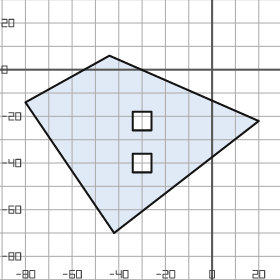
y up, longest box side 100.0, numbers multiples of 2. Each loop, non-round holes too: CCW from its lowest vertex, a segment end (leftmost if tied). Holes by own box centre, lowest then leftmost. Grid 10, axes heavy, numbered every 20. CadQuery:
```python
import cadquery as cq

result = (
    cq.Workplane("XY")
    .moveTo(-42.0, -70.0)
    .lineTo(20.0, -22.0)
    .lineTo(-44.0, 6.0)
    .lineTo(-80.0, -14.0)
    .close()
    .moveTo(-34.0, -44.0)
    .lineTo(-26.0, -44.0)
    .lineTo(-26.0, -36.0)
    .lineTo(-34.0, -36.0)
    .close()
    .moveTo(-34.0, -26.0)
    .lineTo(-26.0, -26.0)
    .lineTo(-26.0, -18.0)
    .lineTo(-34.0, -18.0)
    .close()
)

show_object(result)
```